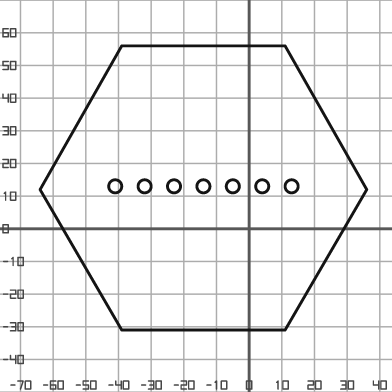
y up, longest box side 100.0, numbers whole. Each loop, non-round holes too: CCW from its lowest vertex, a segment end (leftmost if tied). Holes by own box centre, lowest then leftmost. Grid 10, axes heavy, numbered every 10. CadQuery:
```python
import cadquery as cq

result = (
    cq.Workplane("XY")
    .moveTo(-39.0, -31.0)
    .lineTo(11.0, -31.0)
    .lineTo(36.0, 12.0)
    .lineTo(11.0, 56.0)
    .lineTo(-39.0, 56.0)
    .lineTo(-64.0, 12.0)
    .close()
    .moveTo(-41.0, 13.0)
    .circle(2.0)
    .moveTo(-32.0, 13.0)
    .circle(2.0)
    .moveTo(-23.0, 13.0)
    .circle(2.0)
    .moveTo(-14.0, 13.0)
    .circle(2.0)
    .moveTo(-5.0, 13.0)
    .circle(2.0)
    .moveTo(4.0, 13.0)
    .circle(2.0)
    .moveTo(13.0, 13.0)
    .circle(2.0)
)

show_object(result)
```